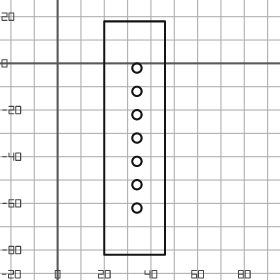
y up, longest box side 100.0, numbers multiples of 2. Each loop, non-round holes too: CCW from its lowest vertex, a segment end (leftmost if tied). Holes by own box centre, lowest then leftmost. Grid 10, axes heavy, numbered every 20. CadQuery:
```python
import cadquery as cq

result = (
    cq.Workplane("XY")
    .moveTo(20.0, -82.0)
    .lineTo(46.0, -82.0)
    .lineTo(46.0, 18.0)
    .lineTo(20.0, 18.0)
    .close()
    .moveTo(34.0, -62.0)
    .circle(2.0)
    .moveTo(34.0, -52.0)
    .circle(2.0)
    .moveTo(34.0, -42.0)
    .circle(2.0)
    .moveTo(34.0, -32.0)
    .circle(2.0)
    .moveTo(34.0, -22.0)
    .circle(2.0)
    .moveTo(34.0, -12.0)
    .circle(2.0)
    .moveTo(34.0, -2.0)
    .circle(2.0)
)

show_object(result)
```